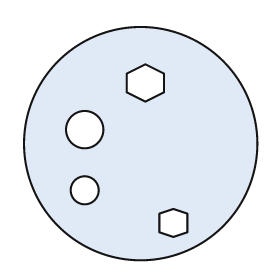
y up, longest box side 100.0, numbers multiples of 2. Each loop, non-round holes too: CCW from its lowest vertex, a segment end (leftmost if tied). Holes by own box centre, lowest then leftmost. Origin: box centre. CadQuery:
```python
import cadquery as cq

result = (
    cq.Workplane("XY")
    .moveTo(0.0, 0.0)
    .circle(50.0)
    .moveTo(14.0, -40.0)
    .lineTo(20.0, -38.0)
    .lineTo(20.0, -30.0)
    .lineTo(14.0, -28.0)
    .lineTo(8.0, -30.0)
    .lineTo(8.0, -38.0)
    .close()
    .moveTo(-24.0, -20.0)
    .circle(6.0)
    .moveTo(-24.0, 6.0)
    .circle(8.0)
    .moveTo(2.0, 18.0)
    .lineTo(10.0, 22.0)
    .lineTo(10.0, 30.0)
    .lineTo(2.0, 34.0)
    .lineTo(-6.0, 30.0)
    .lineTo(-6.0, 22.0)
    .close()
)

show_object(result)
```